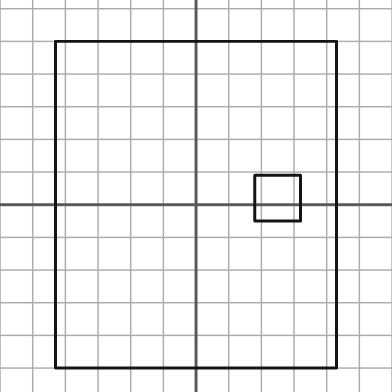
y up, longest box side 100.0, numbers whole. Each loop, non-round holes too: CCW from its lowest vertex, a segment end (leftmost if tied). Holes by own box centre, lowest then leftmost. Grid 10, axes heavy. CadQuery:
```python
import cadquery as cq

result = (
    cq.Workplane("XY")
    .moveTo(-43.0, -50.0)
    .lineTo(43.0, -50.0)
    .lineTo(43.0, 50.0)
    .lineTo(-43.0, 50.0)
    .close()
    .moveTo(18.0, -5.0)
    .lineTo(32.0, -5.0)
    .lineTo(32.0, 9.0)
    .lineTo(18.0, 9.0)
    .close()
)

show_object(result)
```